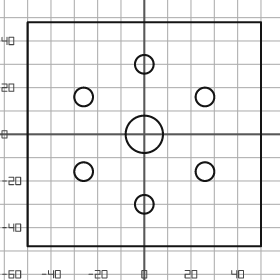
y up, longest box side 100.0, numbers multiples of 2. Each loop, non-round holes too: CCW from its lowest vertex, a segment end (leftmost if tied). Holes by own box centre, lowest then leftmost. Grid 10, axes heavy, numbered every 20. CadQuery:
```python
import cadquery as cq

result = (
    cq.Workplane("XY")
    .moveTo(-50.0, -48.0)
    .lineTo(50.0, -48.0)
    .lineTo(50.0, 48.0)
    .lineTo(-50.0, 48.0)
    .close()
    .moveTo(0.0, -30.0)
    .circle(4.0)
    .moveTo(-26.0, -16.0)
    .circle(4.0)
    .moveTo(26.0, -16.0)
    .circle(4.0)
    .moveTo(0.0, 0.0)
    .circle(8.0)
    .moveTo(-26.0, 16.0)
    .circle(4.0)
    .moveTo(26.0, 16.0)
    .circle(4.0)
    .moveTo(0.0, 30.0)
    .circle(4.0)
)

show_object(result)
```